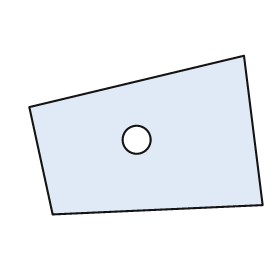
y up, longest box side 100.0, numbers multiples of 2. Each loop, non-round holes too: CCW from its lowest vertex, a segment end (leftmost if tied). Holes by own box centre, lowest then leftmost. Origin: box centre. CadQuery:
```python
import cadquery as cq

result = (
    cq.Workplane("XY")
    .moveTo(-40.0, -34.0)
    .lineTo(50.0, -30.0)
    .lineTo(42.0, 34.0)
    .lineTo(-50.0, 12.0)
    .close()
    .moveTo(-4.0, -2.0)
    .circle(6.0)
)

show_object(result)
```